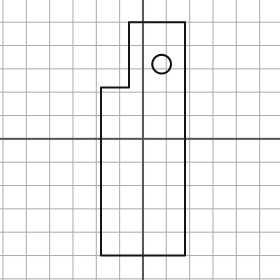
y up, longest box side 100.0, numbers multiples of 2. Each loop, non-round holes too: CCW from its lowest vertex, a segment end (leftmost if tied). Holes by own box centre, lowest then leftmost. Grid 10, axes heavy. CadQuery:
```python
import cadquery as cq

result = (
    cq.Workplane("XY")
    .moveTo(-18.0, -50.0)
    .lineTo(18.0, -50.0)
    .lineTo(18.0, 50.0)
    .lineTo(-6.0, 50.0)
    .lineTo(-6.0, 22.0)
    .lineTo(-18.0, 22.0)
    .close()
    .moveTo(8.0, 32.0)
    .circle(4.0)
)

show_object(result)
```